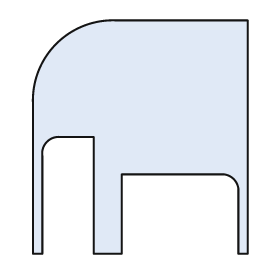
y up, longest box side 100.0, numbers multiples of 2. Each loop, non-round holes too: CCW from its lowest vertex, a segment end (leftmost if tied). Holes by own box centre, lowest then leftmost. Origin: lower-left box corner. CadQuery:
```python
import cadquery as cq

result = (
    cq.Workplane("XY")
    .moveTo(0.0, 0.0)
    .lineTo(4.0, 0.0)
    .lineTo(4.0, 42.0)
    .threePointArc((6.0, 48.0), (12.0, 50.0))
    .lineTo(26.0, 50.0)
    .lineTo(26.0, 0.0)
    .lineTo(38.0, 0.0)
    .lineTo(38.0, 34.0)
    .lineTo(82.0, 34.0)
    .threePointArc((86.0, 32.0), (88.0, 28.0))
    .lineTo(88.0, 0.0)
    .lineTo(92.0, 0.0)
    .lineTo(92.0, 100.0)
    .lineTo(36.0, 100.0)
    .threePointArc((10.0, 90.0), (0.0, 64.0))
    .close()
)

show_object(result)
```